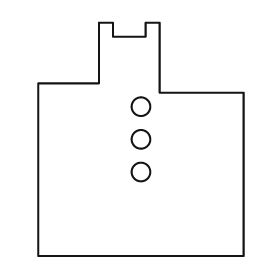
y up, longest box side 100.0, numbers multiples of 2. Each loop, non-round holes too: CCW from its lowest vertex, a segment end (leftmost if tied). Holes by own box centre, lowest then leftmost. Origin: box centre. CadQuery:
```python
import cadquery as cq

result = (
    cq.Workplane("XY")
    .moveTo(-44.0, -50.0)
    .lineTo(44.0, -50.0)
    .lineTo(44.0, 20.0)
    .lineTo(8.0, 20.0)
    .lineTo(8.0, 50.0)
    .lineTo(2.0, 50.0)
    .lineTo(2.0, 44.0)
    .lineTo(-12.0, 44.0)
    .lineTo(-12.0, 50.0)
    .lineTo(-18.0, 50.0)
    .lineTo(-18.0, 24.0)
    .lineTo(-44.0, 24.0)
    .close()
    .moveTo(0.0, -14.0)
    .circle(4.0)
    .moveTo(0.0, 0.0)
    .circle(4.0)
    .moveTo(0.0, 14.0)
    .circle(4.0)
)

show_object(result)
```